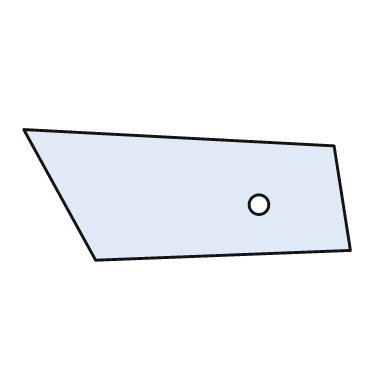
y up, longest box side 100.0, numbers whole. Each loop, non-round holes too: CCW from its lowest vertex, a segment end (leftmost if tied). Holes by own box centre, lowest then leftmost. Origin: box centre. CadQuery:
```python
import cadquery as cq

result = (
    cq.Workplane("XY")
    .moveTo(-28.0, -20.0)
    .lineTo(50.0, -17.0)
    .lineTo(45.0, 15.0)
    .lineTo(-50.0, 20.0)
    .close()
    .moveTo(22.0, -3.0)
    .circle(3.0)
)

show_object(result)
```